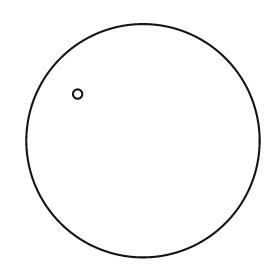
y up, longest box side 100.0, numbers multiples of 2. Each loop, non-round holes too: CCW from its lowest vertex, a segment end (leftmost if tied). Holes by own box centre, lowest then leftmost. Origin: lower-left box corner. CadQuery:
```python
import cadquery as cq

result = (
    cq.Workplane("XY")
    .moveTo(50.0, 50.0)
    .circle(50.0)
    .moveTo(22.0, 70.0)
    .circle(2.0)
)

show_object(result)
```